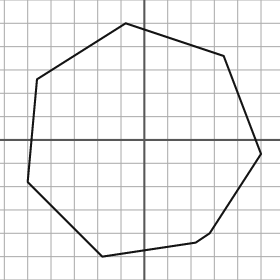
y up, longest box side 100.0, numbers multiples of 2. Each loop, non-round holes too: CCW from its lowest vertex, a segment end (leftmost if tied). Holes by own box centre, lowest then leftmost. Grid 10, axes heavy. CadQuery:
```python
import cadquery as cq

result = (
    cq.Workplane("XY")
    .moveTo(-18.0, -50.0)
    .lineTo(22.0, -44.0)
    .lineTo(28.0, -40.0)
    .lineTo(50.0, -6.0)
    .lineTo(34.0, 36.0)
    .lineTo(-8.0, 50.0)
    .lineTo(-46.0, 26.0)
    .lineTo(-50.0, -18.0)
    .close()
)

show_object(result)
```